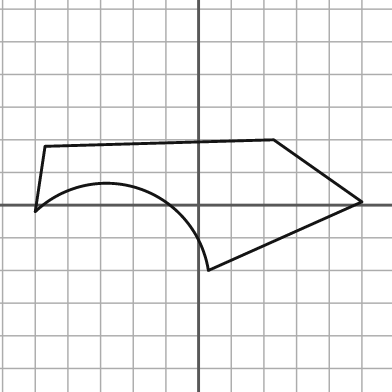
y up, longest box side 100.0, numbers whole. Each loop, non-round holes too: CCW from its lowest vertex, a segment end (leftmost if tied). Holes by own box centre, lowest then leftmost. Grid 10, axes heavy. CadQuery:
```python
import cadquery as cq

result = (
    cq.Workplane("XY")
    .moveTo(3.0, -20.0)
    .lineTo(50.0, 1.0)
    .lineTo(23.0, 20.0)
    .lineTo(-47.0, 18.0)
    .lineTo(-50.0, -2.0)
    .threePointArc((-18.0, 5.0), (3.0, -20.0))
    .close()
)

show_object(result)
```